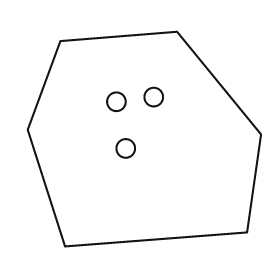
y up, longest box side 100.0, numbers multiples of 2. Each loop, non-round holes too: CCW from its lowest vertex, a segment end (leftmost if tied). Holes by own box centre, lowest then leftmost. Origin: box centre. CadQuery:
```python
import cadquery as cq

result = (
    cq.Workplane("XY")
    .moveTo(-34.0, -46.0)
    .lineTo(44.0, -40.0)
    .lineTo(50.0, 2.0)
    .lineTo(14.0, 46.0)
    .lineTo(-36.0, 42.0)
    .lineTo(-50.0, 4.0)
    .close()
    .moveTo(-8.0, -4.0)
    .circle(4.0)
    .moveTo(-12.0, 16.0)
    .circle(4.0)
    .moveTo(4.0, 18.0)
    .circle(4.0)
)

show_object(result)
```